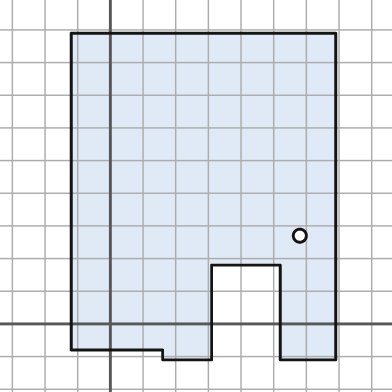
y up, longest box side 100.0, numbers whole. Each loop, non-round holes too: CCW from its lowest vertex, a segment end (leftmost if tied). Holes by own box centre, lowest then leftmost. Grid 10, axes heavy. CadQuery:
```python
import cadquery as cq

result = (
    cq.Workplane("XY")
    .moveTo(16.0, -11.0)
    .lineTo(31.0, -11.0)
    .lineTo(31.0, 18.0)
    .lineTo(52.0, 18.0)
    .lineTo(52.0, -11.0)
    .lineTo(69.0, -11.0)
    .lineTo(69.0, 89.0)
    .lineTo(-12.0, 89.0)
    .lineTo(-12.0, -8.0)
    .lineTo(16.0, -8.0)
    .close()
    .moveTo(58.0, 27.0)
    .circle(2.0)
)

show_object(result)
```